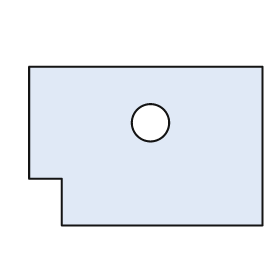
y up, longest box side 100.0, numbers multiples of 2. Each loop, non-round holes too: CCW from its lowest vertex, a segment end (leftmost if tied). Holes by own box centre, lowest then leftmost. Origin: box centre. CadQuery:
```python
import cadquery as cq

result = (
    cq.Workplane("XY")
    .moveTo(-36.0, -34.0)
    .lineTo(50.0, -34.0)
    .lineTo(50.0, 34.0)
    .lineTo(-50.0, 34.0)
    .lineTo(-50.0, -14.0)
    .lineTo(-36.0, -14.0)
    .close()
    .moveTo(2.0, 10.0)
    .circle(8.0)
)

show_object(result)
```